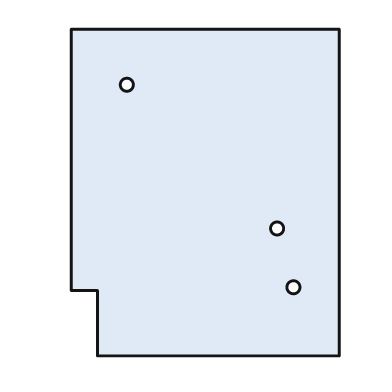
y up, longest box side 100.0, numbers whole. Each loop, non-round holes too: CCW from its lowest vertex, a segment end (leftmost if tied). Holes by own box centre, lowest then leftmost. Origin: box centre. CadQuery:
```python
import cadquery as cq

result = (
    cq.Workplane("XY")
    .moveTo(-33.0, -50.0)
    .lineTo(41.0, -50.0)
    .lineTo(41.0, 50.0)
    .lineTo(-41.0, 50.0)
    .lineTo(-41.0, -30.0)
    .lineTo(-33.0, -30.0)
    .close()
    .moveTo(27.0, -29.0)
    .circle(2.0)
    .moveTo(22.0, -11.0)
    .circle(2.0)
    .moveTo(-24.0, 33.0)
    .circle(2.0)
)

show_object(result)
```